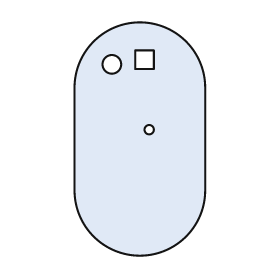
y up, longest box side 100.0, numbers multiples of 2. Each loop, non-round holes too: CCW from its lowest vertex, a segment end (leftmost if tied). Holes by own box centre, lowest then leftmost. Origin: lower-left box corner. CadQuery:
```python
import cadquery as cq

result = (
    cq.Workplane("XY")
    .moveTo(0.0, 28.0)
    .threePointArc((28.0, 0.0), (56.0, 28.0))
    .lineTo(56.0, 72.0)
    .threePointArc((28.0, 100.0), (0.0, 72.0))
    .close()
    .moveTo(32.0, 54.0)
    .circle(2.0)
    .moveTo(16.0, 82.0)
    .circle(4.0)
    .moveTo(26.0, 80.0)
    .lineTo(34.0, 80.0)
    .lineTo(34.0, 88.0)
    .lineTo(26.0, 88.0)
    .close()
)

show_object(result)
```